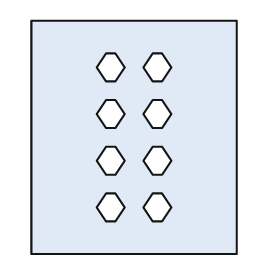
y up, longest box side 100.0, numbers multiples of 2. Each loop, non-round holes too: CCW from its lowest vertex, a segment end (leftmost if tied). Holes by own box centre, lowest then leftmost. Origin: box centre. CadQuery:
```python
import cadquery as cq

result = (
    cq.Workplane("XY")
    .moveTo(-44.0, -50.0)
    .lineTo(44.0, -50.0)
    .lineTo(44.0, 50.0)
    .lineTo(-44.0, 50.0)
    .close()
    .moveTo(-12.0, -36.0)
    .lineTo(-8.0, -36.0)
    .lineTo(-4.0, -30.0)
    .lineTo(-8.0, -24.0)
    .lineTo(-12.0, -24.0)
    .lineTo(-16.0, -30.0)
    .close()
    .moveTo(8.0, -36.0)
    .lineTo(12.0, -36.0)
    .lineTo(16.0, -30.0)
    .lineTo(12.0, -24.0)
    .lineTo(8.0, -24.0)
    .lineTo(4.0, -30.0)
    .close()
    .moveTo(-12.0, -16.0)
    .lineTo(-8.0, -16.0)
    .lineTo(-4.0, -10.0)
    .lineTo(-8.0, -4.0)
    .lineTo(-12.0, -4.0)
    .lineTo(-16.0, -10.0)
    .close()
    .moveTo(8.0, -16.0)
    .lineTo(12.0, -16.0)
    .lineTo(16.0, -10.0)
    .lineTo(12.0, -4.0)
    .lineTo(8.0, -4.0)
    .lineTo(4.0, -10.0)
    .close()
    .moveTo(-12.0, 4.0)
    .lineTo(-8.0, 4.0)
    .lineTo(-4.0, 10.0)
    .lineTo(-8.0, 16.0)
    .lineTo(-12.0, 16.0)
    .lineTo(-16.0, 10.0)
    .close()
    .moveTo(8.0, 4.0)
    .lineTo(12.0, 4.0)
    .lineTo(16.0, 10.0)
    .lineTo(12.0, 16.0)
    .lineTo(8.0, 16.0)
    .lineTo(4.0, 10.0)
    .close()
    .moveTo(-12.0, 24.0)
    .lineTo(-8.0, 24.0)
    .lineTo(-4.0, 30.0)
    .lineTo(-8.0, 36.0)
    .lineTo(-12.0, 36.0)
    .lineTo(-16.0, 30.0)
    .close()
    .moveTo(8.0, 24.0)
    .lineTo(12.0, 24.0)
    .lineTo(16.0, 30.0)
    .lineTo(12.0, 36.0)
    .lineTo(8.0, 36.0)
    .lineTo(4.0, 30.0)
    .close()
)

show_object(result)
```